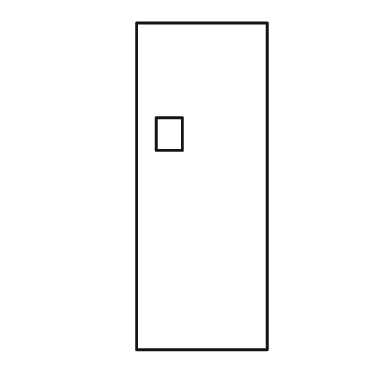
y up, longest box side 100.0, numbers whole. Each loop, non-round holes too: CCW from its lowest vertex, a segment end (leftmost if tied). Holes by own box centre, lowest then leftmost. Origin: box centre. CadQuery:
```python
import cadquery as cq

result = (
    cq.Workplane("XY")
    .moveTo(-20.0, -50.0)
    .lineTo(20.0, -50.0)
    .lineTo(20.0, 50.0)
    .lineTo(-20.0, 50.0)
    .close()
    .moveTo(-14.0, 11.0)
    .lineTo(-6.0, 11.0)
    .lineTo(-6.0, 21.0)
    .lineTo(-14.0, 21.0)
    .close()
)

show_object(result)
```